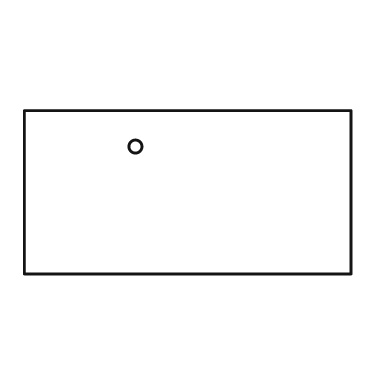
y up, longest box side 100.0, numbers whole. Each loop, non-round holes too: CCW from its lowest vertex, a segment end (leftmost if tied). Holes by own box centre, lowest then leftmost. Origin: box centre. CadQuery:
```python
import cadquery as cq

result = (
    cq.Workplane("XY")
    .moveTo(-50.0, -25.0)
    .lineTo(50.0, -25.0)
    .lineTo(50.0, 25.0)
    .lineTo(-50.0, 25.0)
    .close()
    .moveTo(-16.0, 14.0)
    .circle(2.0)
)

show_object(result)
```